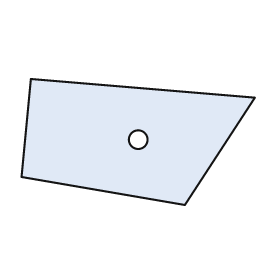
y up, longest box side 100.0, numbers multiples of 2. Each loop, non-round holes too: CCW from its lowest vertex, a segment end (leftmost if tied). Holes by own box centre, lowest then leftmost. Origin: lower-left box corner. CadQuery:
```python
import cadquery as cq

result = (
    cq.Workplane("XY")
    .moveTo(70.0, 0.0)
    .lineTo(100.0, 46.0)
    .lineTo(4.0, 54.0)
    .lineTo(0.0, 12.0)
    .close()
    .moveTo(50.0, 28.0)
    .circle(4.0)
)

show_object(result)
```